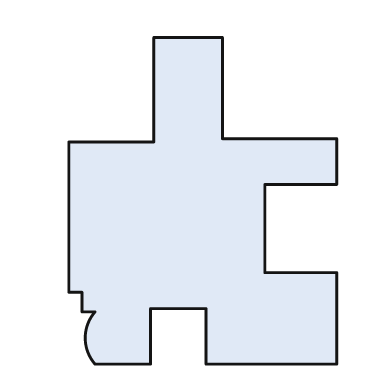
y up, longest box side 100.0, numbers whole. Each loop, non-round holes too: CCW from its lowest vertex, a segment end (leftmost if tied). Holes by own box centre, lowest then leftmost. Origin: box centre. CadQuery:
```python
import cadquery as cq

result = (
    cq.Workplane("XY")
    .moveTo(-33.0, -50.0)
    .lineTo(-16.0, -50.0)
    .lineTo(-16.0, -33.0)
    .lineTo(1.0, -33.0)
    .lineTo(1.0, -50.0)
    .lineTo(41.0, -50.0)
    .lineTo(41.0, -22.0)
    .lineTo(19.0, -22.0)
    .lineTo(19.0, 5.0)
    .lineTo(41.0, 5.0)
    .lineTo(41.0, 19.0)
    .lineTo(6.0, 19.0)
    .lineTo(6.0, 50.0)
    .lineTo(-15.0, 50.0)
    .lineTo(-15.0, 18.0)
    .lineTo(-41.0, 18.0)
    .lineTo(-41.0, -28.0)
    .lineTo(-37.0, -28.0)
    .lineTo(-37.0, -34.0)
    .lineTo(-33.0, -34.0)
    .threePointArc((-36.0, -42.0), (-33.0, -50.0))
    .close()
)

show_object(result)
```